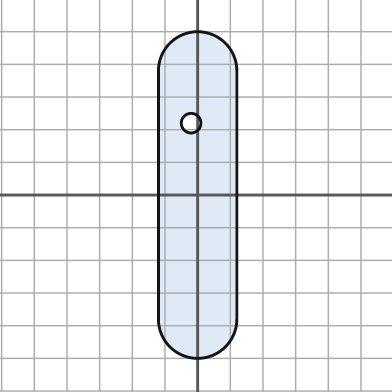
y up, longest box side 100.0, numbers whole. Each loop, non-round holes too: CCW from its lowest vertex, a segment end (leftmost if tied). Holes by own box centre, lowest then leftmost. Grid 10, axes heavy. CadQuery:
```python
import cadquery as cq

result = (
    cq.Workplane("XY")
    .moveTo(-12.0, -38.0)
    .threePointArc((0.0, -50.0), (12.0, -38.0))
    .lineTo(12.0, 38.0)
    .threePointArc((0.0, 50.0), (-12.0, 38.0))
    .close()
    .moveTo(-2.0, 22.0)
    .circle(3.0)
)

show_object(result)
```